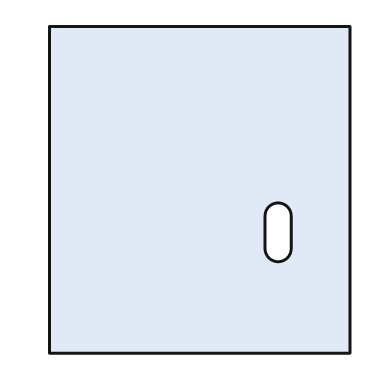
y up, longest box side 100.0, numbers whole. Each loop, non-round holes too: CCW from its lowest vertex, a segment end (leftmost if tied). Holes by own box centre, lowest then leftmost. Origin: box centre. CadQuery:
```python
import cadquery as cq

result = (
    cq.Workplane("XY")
    .moveTo(-46.0, -50.0)
    .lineTo(46.0, -50.0)
    .lineTo(46.0, 50.0)
    .lineTo(-46.0, 50.0)
    .close()
    .moveTo(20.0, -18.0)
    .threePointArc((24.0, -22.0), (28.0, -18.0))
    .lineTo(28.0, -8.0)
    .threePointArc((24.0, -4.0), (20.0, -8.0))
    .close()
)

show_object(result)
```